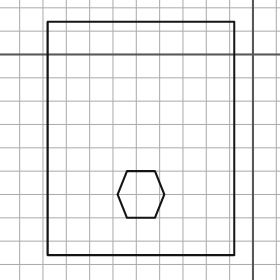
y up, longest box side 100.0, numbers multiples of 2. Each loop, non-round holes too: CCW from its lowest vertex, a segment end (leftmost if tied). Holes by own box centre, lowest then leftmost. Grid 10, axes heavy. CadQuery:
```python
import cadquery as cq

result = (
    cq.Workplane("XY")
    .moveTo(-88.0, -86.0)
    .lineTo(-8.0, -86.0)
    .lineTo(-8.0, 14.0)
    .lineTo(-88.0, 14.0)
    .close()
    .moveTo(-54.0, -70.0)
    .lineTo(-42.0, -70.0)
    .lineTo(-38.0, -60.0)
    .lineTo(-42.0, -50.0)
    .lineTo(-54.0, -50.0)
    .lineTo(-58.0, -60.0)
    .close()
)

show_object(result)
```